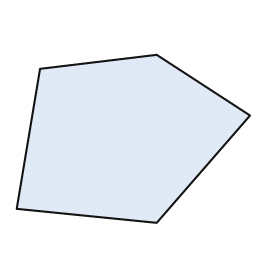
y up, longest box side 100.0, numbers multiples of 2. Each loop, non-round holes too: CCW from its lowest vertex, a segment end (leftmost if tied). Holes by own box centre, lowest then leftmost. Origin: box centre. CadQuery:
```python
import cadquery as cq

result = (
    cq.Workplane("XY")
    .moveTo(10.0, -36.0)
    .lineTo(50.0, 10.0)
    .lineTo(10.0, 36.0)
    .lineTo(-40.0, 30.0)
    .lineTo(-50.0, -30.0)
    .close()
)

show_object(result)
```